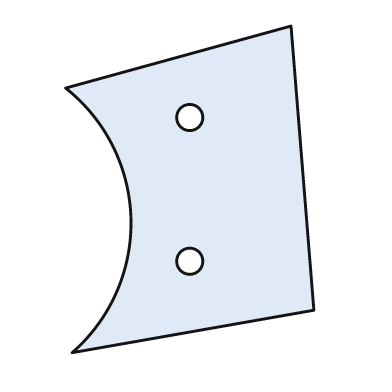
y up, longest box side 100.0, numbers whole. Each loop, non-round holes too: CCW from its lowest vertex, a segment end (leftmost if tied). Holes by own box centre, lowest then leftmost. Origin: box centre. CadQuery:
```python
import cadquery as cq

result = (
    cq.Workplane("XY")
    .moveTo(-36.0, -50.0)
    .lineTo(38.0, -37.0)
    .lineTo(31.0, 50.0)
    .lineTo(-38.0, 31.0)
    .threePointArc((-18.0, -9.0), (-36.0, -50.0))
    .close()
    .moveTo(0.0, -22.0)
    .circle(4.0)
    .moveTo(0.0, 22.0)
    .circle(4.0)
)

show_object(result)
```